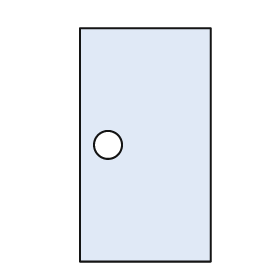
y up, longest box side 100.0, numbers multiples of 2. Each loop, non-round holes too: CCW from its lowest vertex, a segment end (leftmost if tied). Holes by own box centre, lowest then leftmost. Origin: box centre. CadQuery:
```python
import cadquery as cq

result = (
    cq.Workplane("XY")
    .moveTo(-28.0, -50.0)
    .lineTo(28.0, -50.0)
    .lineTo(28.0, 50.0)
    .lineTo(-28.0, 50.0)
    .close()
    .moveTo(-16.0, 0.0)
    .circle(6.0)
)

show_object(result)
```